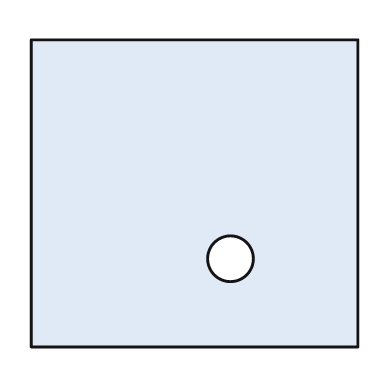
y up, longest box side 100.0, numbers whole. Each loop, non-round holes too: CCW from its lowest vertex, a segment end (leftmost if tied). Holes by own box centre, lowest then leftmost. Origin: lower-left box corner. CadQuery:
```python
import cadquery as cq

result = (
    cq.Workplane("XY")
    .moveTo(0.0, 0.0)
    .lineTo(100.0, 0.0)
    .lineTo(100.0, 94.0)
    .lineTo(0.0, 94.0)
    .close()
    .moveTo(61.0, 27.0)
    .circle(7.0)
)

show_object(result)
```